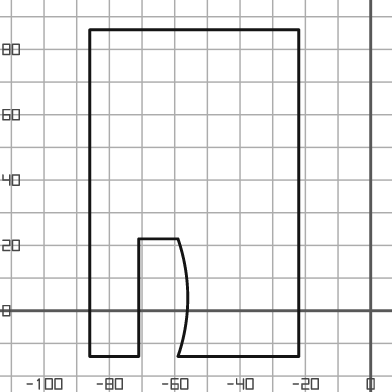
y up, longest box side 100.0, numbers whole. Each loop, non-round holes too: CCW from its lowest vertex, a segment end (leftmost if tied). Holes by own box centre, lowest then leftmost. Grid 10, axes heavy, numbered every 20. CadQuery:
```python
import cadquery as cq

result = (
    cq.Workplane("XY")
    .moveTo(-86.0, -14.0)
    .lineTo(-71.0, -14.0)
    .lineTo(-71.0, 22.0)
    .lineTo(-59.0, 22.0)
    .threePointArc((-56.0, 4.0), (-59.0, -14.0))
    .lineTo(-22.0, -14.0)
    .lineTo(-22.0, 86.0)
    .lineTo(-86.0, 86.0)
    .close()
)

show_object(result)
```